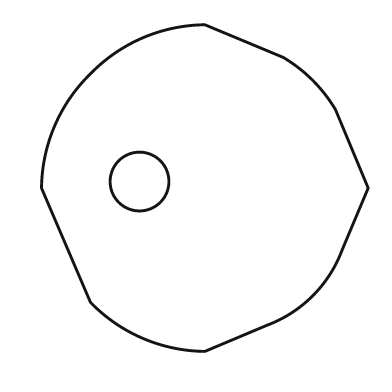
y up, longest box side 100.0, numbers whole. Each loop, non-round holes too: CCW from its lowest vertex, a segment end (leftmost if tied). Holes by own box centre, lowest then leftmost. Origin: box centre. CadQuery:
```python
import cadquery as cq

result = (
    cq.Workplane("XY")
    .moveTo(0.0, -50.0)
    .lineTo(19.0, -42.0)
    .threePointArc((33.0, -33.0), (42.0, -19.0))
    .lineTo(50.0, 0.0)
    .lineTo(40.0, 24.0)
    .threePointArc((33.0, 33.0), (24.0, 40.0))
    .lineTo(0.0, 50.0)
    .threePointArc((-19.0, 46.0), (-35.0, 35.0))
    .threePointArc((-46.0, 19.0), (-50.0, 0.0))
    .lineTo(-35.0, -35.0)
    .threePointArc((-19.0, -46.0), (0.0, -50.0))
    .close()
    .moveTo(-20.0, 2.0)
    .circle(9.0)
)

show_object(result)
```